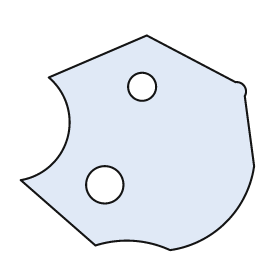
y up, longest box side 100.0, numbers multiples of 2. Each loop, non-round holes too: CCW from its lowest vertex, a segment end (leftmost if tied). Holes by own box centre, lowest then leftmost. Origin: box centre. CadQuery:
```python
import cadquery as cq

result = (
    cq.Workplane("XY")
    .moveTo(14.0, -46.0)
    .threePointArc((38.0, -34.0), (50.0, -10.0))
    .lineTo(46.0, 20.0)
    .threePointArc((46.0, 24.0), (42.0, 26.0))
    .lineTo(4.0, 46.0)
    .lineTo(-38.0, 28.0)
    .threePointArc((-30.0, 2.0), (-50.0, -16.0))
    .lineTo(-18.0, -44.0)
    .threePointArc((-2.0, -42.0), (14.0, -46.0))
    .close()
    .moveTo(-14.0, -18.0)
    .circle(8.0)
    .moveTo(2.0, 24.0)
    .circle(6.0)
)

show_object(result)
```